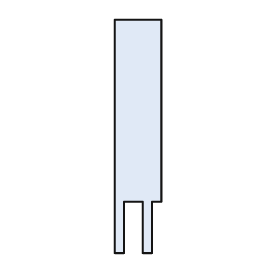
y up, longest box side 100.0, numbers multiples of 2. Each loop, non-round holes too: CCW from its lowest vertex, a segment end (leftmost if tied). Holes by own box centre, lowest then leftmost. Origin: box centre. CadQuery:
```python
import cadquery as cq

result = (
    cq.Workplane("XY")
    .moveTo(-10.0, -50.0)
    .lineTo(-6.0, -50.0)
    .lineTo(-6.0, -28.0)
    .lineTo(2.0, -28.0)
    .lineTo(2.0, -50.0)
    .lineTo(6.0, -50.0)
    .lineTo(6.0, -28.0)
    .lineTo(10.0, -28.0)
    .lineTo(10.0, 50.0)
    .lineTo(-10.0, 50.0)
    .close()
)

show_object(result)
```